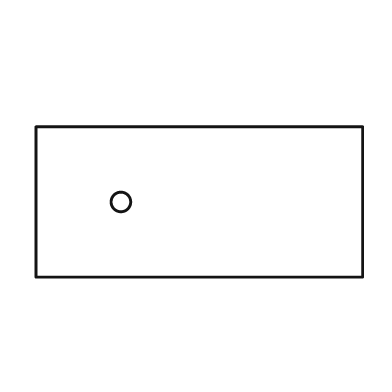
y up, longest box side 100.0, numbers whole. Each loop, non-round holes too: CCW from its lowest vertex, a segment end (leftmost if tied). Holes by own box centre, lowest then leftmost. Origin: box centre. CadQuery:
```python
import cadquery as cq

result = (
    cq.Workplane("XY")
    .moveTo(-50.0, -23.0)
    .lineTo(50.0, -23.0)
    .lineTo(50.0, 23.0)
    .lineTo(-50.0, 23.0)
    .close()
    .moveTo(-24.0, 0.0)
    .circle(3.0)
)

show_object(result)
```